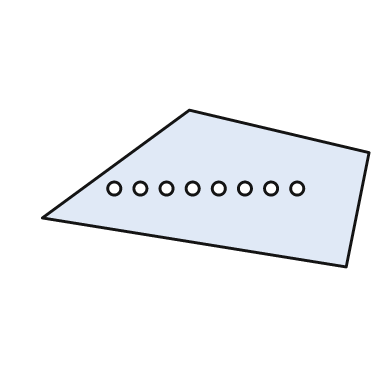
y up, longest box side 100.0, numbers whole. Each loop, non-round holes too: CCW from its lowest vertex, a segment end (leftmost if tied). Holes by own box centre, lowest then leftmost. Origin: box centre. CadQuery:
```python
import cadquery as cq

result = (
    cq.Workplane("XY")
    .moveTo(43.0, -24.0)
    .lineTo(50.0, 11.0)
    .lineTo(-5.0, 24.0)
    .lineTo(-50.0, -9.0)
    .close()
    .moveTo(-28.0, 0.0)
    .circle(2.0)
    .moveTo(-20.0, 0.0)
    .circle(2.0)
    .moveTo(-12.0, 0.0)
    .circle(2.0)
    .moveTo(-4.0, 0.0)
    .circle(2.0)
    .moveTo(4.0, 0.0)
    .circle(2.0)
    .moveTo(12.0, 0.0)
    .circle(2.0)
    .moveTo(20.0, 0.0)
    .circle(2.0)
    .moveTo(28.0, 0.0)
    .circle(2.0)
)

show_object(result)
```